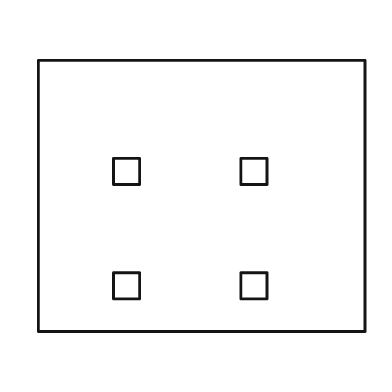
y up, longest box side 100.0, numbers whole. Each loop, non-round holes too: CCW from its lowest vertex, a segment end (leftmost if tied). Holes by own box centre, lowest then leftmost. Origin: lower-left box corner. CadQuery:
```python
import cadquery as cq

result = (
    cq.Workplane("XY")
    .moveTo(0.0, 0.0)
    .lineTo(100.0, 0.0)
    .lineTo(100.0, 83.0)
    .lineTo(0.0, 83.0)
    .close()
    .moveTo(23.0, 10.0)
    .lineTo(31.0, 10.0)
    .lineTo(31.0, 18.0)
    .lineTo(23.0, 18.0)
    .close()
    .moveTo(62.0, 10.0)
    .lineTo(70.0, 10.0)
    .lineTo(70.0, 18.0)
    .lineTo(62.0, 18.0)
    .close()
    .moveTo(23.0, 45.0)
    .lineTo(31.0, 45.0)
    .lineTo(31.0, 53.0)
    .lineTo(23.0, 53.0)
    .close()
    .moveTo(62.0, 45.0)
    .lineTo(70.0, 45.0)
    .lineTo(70.0, 53.0)
    .lineTo(62.0, 53.0)
    .close()
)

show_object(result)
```